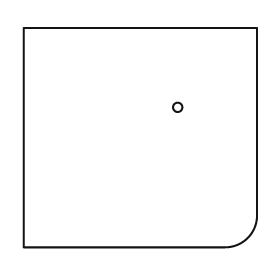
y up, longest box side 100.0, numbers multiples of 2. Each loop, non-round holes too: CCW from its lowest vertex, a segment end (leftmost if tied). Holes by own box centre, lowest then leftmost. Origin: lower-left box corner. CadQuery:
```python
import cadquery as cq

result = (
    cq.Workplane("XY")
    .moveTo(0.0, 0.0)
    .lineTo(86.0, 0.0)
    .threePointArc((96.0, 4.0), (100.0, 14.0))
    .lineTo(100.0, 94.0)
    .lineTo(0.0, 94.0)
    .close()
    .moveTo(66.0, 60.0)
    .circle(2.0)
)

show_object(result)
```